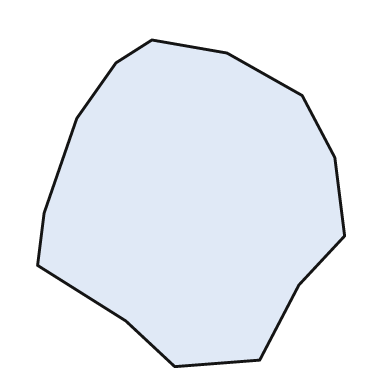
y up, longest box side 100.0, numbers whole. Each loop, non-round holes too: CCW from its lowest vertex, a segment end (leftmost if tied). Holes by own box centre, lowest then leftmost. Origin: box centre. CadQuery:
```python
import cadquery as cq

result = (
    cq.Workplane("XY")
    .moveTo(-5.0, -50.0)
    .lineTo(21.0, -48.0)
    .lineTo(33.0, -25.0)
    .lineTo(47.0, -10.0)
    .lineTo(44.0, 14.0)
    .lineTo(34.0, 33.0)
    .lineTo(11.0, 46.0)
    .lineTo(-12.0, 50.0)
    .lineTo(-23.0, 43.0)
    .lineTo(-35.0, 26.0)
    .lineTo(-45.0, -3.0)
    .lineTo(-47.0, -19.0)
    .lineTo(-20.0, -36.0)
    .close()
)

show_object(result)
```